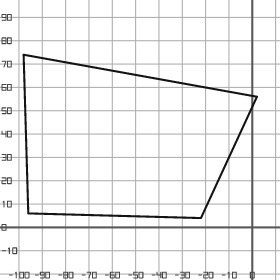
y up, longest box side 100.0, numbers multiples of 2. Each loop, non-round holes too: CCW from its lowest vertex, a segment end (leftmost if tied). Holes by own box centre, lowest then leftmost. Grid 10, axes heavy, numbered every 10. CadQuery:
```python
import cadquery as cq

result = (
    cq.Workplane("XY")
    .moveTo(-22.0, 4.0)
    .lineTo(2.0, 56.0)
    .lineTo(-98.0, 74.0)
    .lineTo(-96.0, 6.0)
    .close()
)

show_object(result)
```